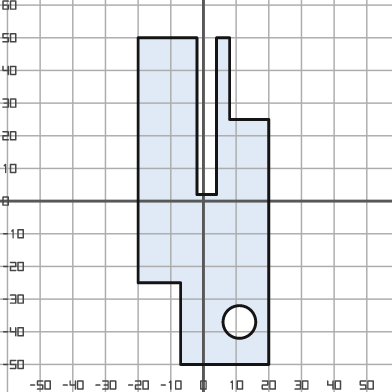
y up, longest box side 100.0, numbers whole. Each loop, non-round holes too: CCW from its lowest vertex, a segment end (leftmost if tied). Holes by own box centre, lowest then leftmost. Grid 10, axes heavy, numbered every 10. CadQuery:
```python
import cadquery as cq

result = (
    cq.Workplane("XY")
    .moveTo(-7.0, -50.0)
    .lineTo(20.0, -50.0)
    .lineTo(20.0, 25.0)
    .lineTo(8.0, 25.0)
    .lineTo(8.0, 50.0)
    .lineTo(4.0, 50.0)
    .lineTo(4.0, 2.0)
    .lineTo(-2.0, 2.0)
    .lineTo(-2.0, 50.0)
    .lineTo(-20.0, 50.0)
    .lineTo(-20.0, -25.0)
    .lineTo(-7.0, -25.0)
    .close()
    .moveTo(11.0, -37.0)
    .circle(5.0)
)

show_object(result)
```